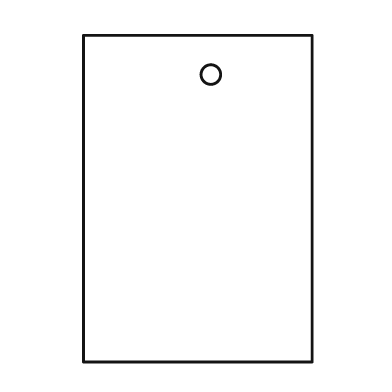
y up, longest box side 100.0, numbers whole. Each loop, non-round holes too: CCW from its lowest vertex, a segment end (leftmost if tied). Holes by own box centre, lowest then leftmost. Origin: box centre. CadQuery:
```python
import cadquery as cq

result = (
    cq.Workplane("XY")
    .moveTo(-35.0, -50.0)
    .lineTo(35.0, -50.0)
    .lineTo(35.0, 50.0)
    .lineTo(-35.0, 50.0)
    .close()
    .moveTo(4.0, 38.0)
    .circle(3.0)
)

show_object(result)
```